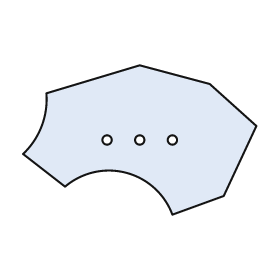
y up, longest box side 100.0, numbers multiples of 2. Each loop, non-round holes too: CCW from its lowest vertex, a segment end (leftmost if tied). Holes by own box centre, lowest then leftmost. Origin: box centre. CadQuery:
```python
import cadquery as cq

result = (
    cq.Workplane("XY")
    .moveTo(14.0, -32.0)
    .lineTo(36.0, -24.0)
    .lineTo(50.0, 6.0)
    .lineTo(30.0, 24.0)
    .lineTo(0.0, 32.0)
    .lineTo(-40.0, 20.0)
    .threePointArc((-42.0, 6.0), (-50.0, -6.0))
    .lineTo(-32.0, -20.0)
    .threePointArc((-6.0, -14.0), (14.0, -32.0))
    .close()
    .moveTo(-14.0, 0.0)
    .circle(2.0)
    .moveTo(0.0, 0.0)
    .circle(2.0)
    .moveTo(14.0, 0.0)
    .circle(2.0)
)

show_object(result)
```